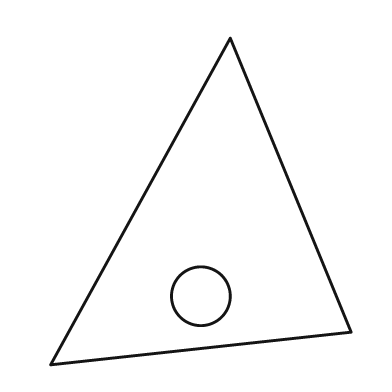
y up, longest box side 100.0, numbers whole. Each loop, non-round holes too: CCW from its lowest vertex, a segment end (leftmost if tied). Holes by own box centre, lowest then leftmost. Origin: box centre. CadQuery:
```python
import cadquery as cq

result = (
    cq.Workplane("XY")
    .moveTo(-46.0, -50.0)
    .lineTo(46.0, -40.0)
    .lineTo(9.0, 50.0)
    .close()
    .moveTo(0.0, -29.0)
    .circle(9.0)
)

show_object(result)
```